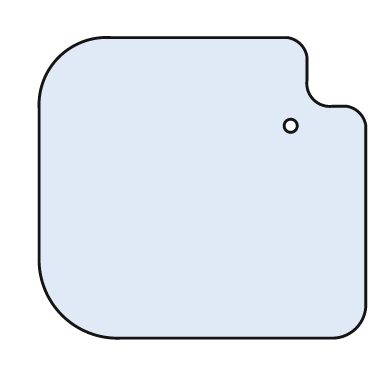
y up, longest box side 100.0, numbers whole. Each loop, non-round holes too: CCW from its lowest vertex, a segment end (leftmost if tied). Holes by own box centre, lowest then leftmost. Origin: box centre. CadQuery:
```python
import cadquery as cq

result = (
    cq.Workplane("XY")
    .moveTo(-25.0, -46.0)
    .lineTo(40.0, -46.0)
    .threePointArc((47.0, -43.0), (50.0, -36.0))
    .lineTo(50.0, 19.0)
    .threePointArc((48.0, 23.0), (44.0, 25.0))
    .lineTo(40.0, 25.0)
    .threePointArc((34.0, 27.0), (32.0, 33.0))
    .lineTo(32.0, 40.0)
    .threePointArc((30.0, 44.0), (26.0, 46.0))
    .lineTo(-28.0, 46.0)
    .threePointArc((-44.0, 40.0), (-50.0, 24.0))
    .lineTo(-50.0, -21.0)
    .threePointArc((-43.0, -39.0), (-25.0, -46.0))
    .close()
    .moveTo(27.0, 19.0)
    .circle(2.0)
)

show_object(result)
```